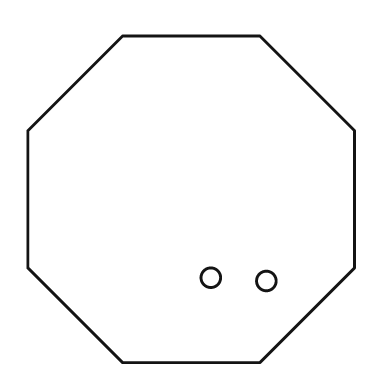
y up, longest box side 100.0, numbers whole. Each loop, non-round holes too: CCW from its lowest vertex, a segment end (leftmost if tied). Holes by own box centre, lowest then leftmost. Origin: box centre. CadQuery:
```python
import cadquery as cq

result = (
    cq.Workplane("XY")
    .moveTo(-21.0, -50.0)
    .lineTo(21.0, -50.0)
    .lineTo(50.0, -21.0)
    .lineTo(50.0, 21.0)
    .lineTo(21.0, 50.0)
    .lineTo(-21.0, 50.0)
    .lineTo(-50.0, 21.0)
    .lineTo(-50.0, -21.0)
    .close()
    .moveTo(23.0, -25.0)
    .circle(3.0)
    .moveTo(6.0, -24.0)
    .circle(3.0)
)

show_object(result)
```